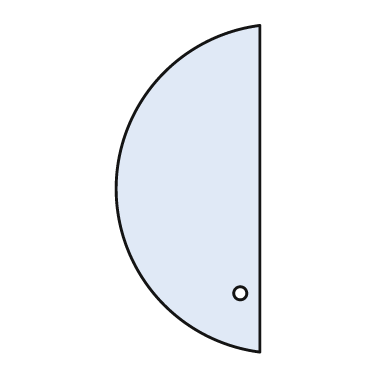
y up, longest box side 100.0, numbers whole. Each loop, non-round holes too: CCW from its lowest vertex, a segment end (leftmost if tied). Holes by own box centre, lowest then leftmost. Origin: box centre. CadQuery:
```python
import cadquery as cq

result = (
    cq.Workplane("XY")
    .moveTo(22.0, -50.0)
    .lineTo(22.0, 50.0)
    .threePointArc((-22.0, 0.0), (22.0, -50.0))
    .close()
    .moveTo(16.0, -32.0)
    .circle(2.0)
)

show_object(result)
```